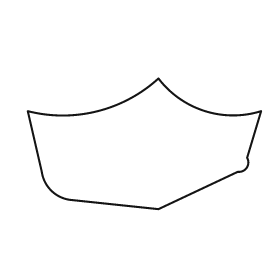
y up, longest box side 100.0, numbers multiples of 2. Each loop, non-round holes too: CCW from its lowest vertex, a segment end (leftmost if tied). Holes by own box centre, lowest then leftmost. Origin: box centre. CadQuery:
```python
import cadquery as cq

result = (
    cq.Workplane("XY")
    .moveTo(6.0, -28.0)
    .lineTo(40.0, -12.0)
    .threePointArc((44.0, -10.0), (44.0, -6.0))
    .lineTo(50.0, 14.0)
    .threePointArc((26.0, 14.0), (6.0, 28.0))
    .threePointArc((-20.0, 14.0), (-50.0, 14.0))
    .lineTo(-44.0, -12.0)
    .threePointArc((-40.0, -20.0), (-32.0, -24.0))
    .close()
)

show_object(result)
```